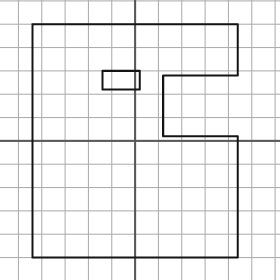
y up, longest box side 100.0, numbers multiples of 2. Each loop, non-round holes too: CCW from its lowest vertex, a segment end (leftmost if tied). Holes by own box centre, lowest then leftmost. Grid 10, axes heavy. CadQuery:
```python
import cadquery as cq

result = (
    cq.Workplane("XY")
    .moveTo(-44.0, -50.0)
    .lineTo(44.0, -50.0)
    .lineTo(44.0, 2.0)
    .lineTo(12.0, 2.0)
    .lineTo(12.0, 28.0)
    .lineTo(44.0, 28.0)
    .lineTo(44.0, 50.0)
    .lineTo(-44.0, 50.0)
    .close()
    .moveTo(-14.0, 22.0)
    .lineTo(2.0, 22.0)
    .lineTo(2.0, 30.0)
    .lineTo(-14.0, 30.0)
    .close()
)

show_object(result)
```